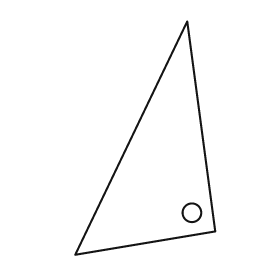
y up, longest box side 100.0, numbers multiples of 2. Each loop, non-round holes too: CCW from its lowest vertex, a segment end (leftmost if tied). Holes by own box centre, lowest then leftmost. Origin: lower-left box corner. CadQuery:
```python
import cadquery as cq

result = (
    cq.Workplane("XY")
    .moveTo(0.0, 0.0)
    .lineTo(60.0, 10.0)
    .lineTo(48.0, 100.0)
    .close()
    .moveTo(50.0, 18.0)
    .circle(4.0)
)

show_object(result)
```